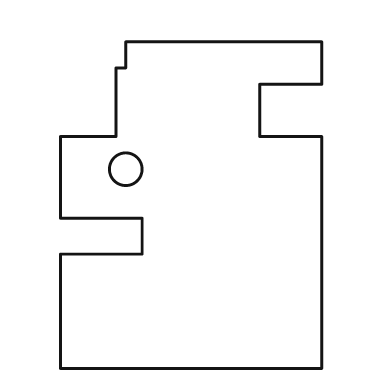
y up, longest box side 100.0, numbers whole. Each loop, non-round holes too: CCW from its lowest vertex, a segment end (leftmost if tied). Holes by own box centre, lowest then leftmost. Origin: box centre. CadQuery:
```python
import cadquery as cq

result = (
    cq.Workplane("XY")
    .moveTo(-40.0, -50.0)
    .lineTo(40.0, -50.0)
    .lineTo(40.0, 21.0)
    .lineTo(21.0, 21.0)
    .lineTo(21.0, 37.0)
    .lineTo(40.0, 37.0)
    .lineTo(40.0, 50.0)
    .lineTo(-20.0, 50.0)
    .lineTo(-20.0, 42.0)
    .lineTo(-23.0, 42.0)
    .lineTo(-23.0, 21.0)
    .lineTo(-40.0, 21.0)
    .lineTo(-40.0, -4.0)
    .lineTo(-15.0, -4.0)
    .lineTo(-15.0, -15.0)
    .lineTo(-40.0, -15.0)
    .close()
    .moveTo(-20.0, 11.0)
    .circle(5.0)
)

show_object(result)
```